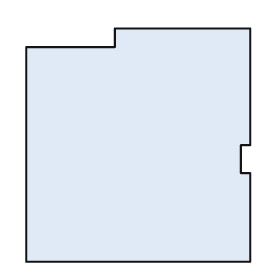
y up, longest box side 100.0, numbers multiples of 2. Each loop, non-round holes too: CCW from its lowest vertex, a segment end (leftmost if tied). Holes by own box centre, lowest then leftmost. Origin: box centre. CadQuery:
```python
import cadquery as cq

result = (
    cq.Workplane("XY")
    .moveTo(-48.0, -50.0)
    .lineTo(48.0, -50.0)
    .lineTo(48.0, -12.0)
    .lineTo(44.0, -12.0)
    .lineTo(44.0, 0.0)
    .lineTo(48.0, 0.0)
    .lineTo(48.0, 50.0)
    .lineTo(-10.0, 50.0)
    .lineTo(-10.0, 42.0)
    .lineTo(-48.0, 42.0)
    .close()
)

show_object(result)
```